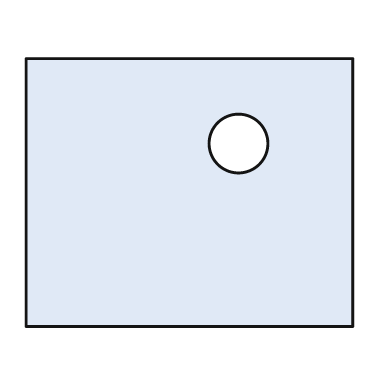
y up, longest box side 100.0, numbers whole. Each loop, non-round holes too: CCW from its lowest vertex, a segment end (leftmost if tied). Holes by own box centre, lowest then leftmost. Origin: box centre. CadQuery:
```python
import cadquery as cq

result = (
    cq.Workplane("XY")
    .moveTo(-50.0, -41.0)
    .lineTo(50.0, -41.0)
    .lineTo(50.0, 41.0)
    .lineTo(-50.0, 41.0)
    .close()
    .moveTo(15.0, 15.0)
    .circle(9.0)
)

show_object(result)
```